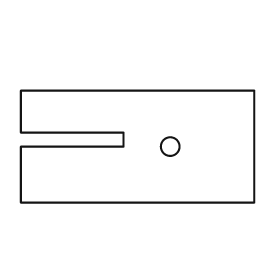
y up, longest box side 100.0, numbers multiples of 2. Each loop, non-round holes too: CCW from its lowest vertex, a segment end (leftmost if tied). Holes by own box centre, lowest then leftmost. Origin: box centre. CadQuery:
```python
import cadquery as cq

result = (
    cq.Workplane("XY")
    .moveTo(-50.0, -24.0)
    .lineTo(50.0, -24.0)
    .lineTo(50.0, 24.0)
    .lineTo(-50.0, 24.0)
    .lineTo(-50.0, 6.0)
    .lineTo(-6.0, 6.0)
    .lineTo(-6.0, 0.0)
    .lineTo(-50.0, 0.0)
    .close()
    .moveTo(14.0, 0.0)
    .circle(4.0)
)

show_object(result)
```